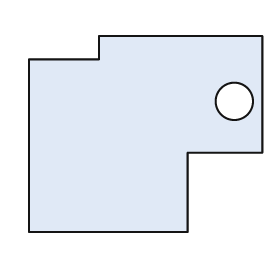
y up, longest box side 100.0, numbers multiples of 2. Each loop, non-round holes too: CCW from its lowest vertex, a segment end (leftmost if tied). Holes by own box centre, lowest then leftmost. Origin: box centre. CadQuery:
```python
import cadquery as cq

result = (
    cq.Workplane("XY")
    .moveTo(-50.0, -42.0)
    .lineTo(18.0, -42.0)
    .lineTo(18.0, -8.0)
    .lineTo(50.0, -8.0)
    .lineTo(50.0, 42.0)
    .lineTo(-20.0, 42.0)
    .lineTo(-20.0, 32.0)
    .lineTo(-50.0, 32.0)
    .close()
    .moveTo(38.0, 14.0)
    .circle(8.0)
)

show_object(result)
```